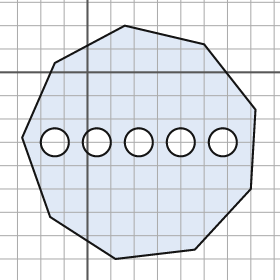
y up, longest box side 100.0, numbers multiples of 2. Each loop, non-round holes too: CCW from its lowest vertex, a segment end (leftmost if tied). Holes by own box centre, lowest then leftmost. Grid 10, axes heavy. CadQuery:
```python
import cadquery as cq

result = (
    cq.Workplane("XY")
    .moveTo(12.0, -80.0)
    .lineTo(46.0, -76.0)
    .lineTo(70.0, -50.0)
    .lineTo(72.0, -16.0)
    .lineTo(50.0, 12.0)
    .lineTo(16.0, 20.0)
    .lineTo(-14.0, 4.0)
    .lineTo(-28.0, -28.0)
    .lineTo(-16.0, -62.0)
    .close()
    .moveTo(-14.0, -30.0)
    .circle(6.0)
    .moveTo(4.0, -30.0)
    .circle(6.0)
    .moveTo(22.0, -30.0)
    .circle(6.0)
    .moveTo(40.0, -30.0)
    .circle(6.0)
    .moveTo(58.0, -30.0)
    .circle(6.0)
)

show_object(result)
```